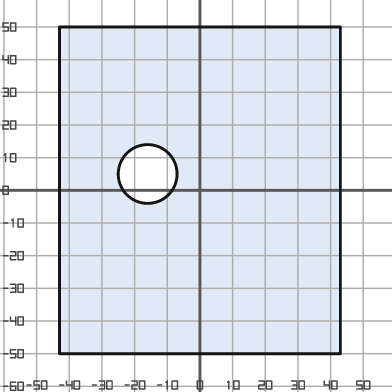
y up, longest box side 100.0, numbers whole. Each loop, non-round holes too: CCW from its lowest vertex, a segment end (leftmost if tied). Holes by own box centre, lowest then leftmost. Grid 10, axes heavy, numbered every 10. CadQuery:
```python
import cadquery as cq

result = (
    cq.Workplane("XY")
    .moveTo(-43.0, -50.0)
    .lineTo(43.0, -50.0)
    .lineTo(43.0, 50.0)
    .lineTo(-43.0, 50.0)
    .close()
    .moveTo(-16.0, 5.0)
    .circle(9.0)
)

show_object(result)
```